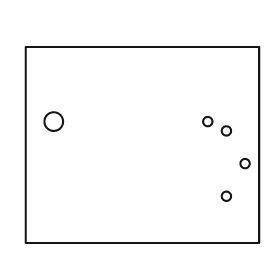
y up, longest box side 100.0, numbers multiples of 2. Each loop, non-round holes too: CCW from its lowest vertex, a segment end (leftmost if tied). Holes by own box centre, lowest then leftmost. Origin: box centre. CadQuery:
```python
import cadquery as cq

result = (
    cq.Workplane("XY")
    .moveTo(-50.0, -42.0)
    .lineTo(50.0, -42.0)
    .lineTo(50.0, 42.0)
    .lineTo(-50.0, 42.0)
    .close()
    .moveTo(36.0, -22.0)
    .circle(2.0)
    .moveTo(44.0, -8.0)
    .circle(2.0)
    .moveTo(36.0, 6.0)
    .circle(2.0)
    .moveTo(-38.0, 10.0)
    .circle(4.0)
    .moveTo(28.0, 10.0)
    .circle(2.0)
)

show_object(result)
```